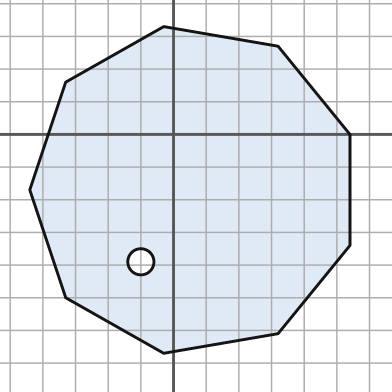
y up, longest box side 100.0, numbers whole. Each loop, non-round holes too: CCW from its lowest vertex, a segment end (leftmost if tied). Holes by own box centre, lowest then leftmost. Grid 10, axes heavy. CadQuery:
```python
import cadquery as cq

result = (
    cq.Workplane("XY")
    .moveTo(-3.0, -67.0)
    .lineTo(32.0, -61.0)
    .lineTo(54.0, -34.0)
    .lineTo(54.0, 0.0)
    .lineTo(32.0, 27.0)
    .lineTo(-3.0, 33.0)
    .lineTo(-33.0, 16.0)
    .lineTo(-44.0, -17.0)
    .lineTo(-33.0, -50.0)
    .close()
    .moveTo(-10.0, -39.0)
    .circle(4.0)
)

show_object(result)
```